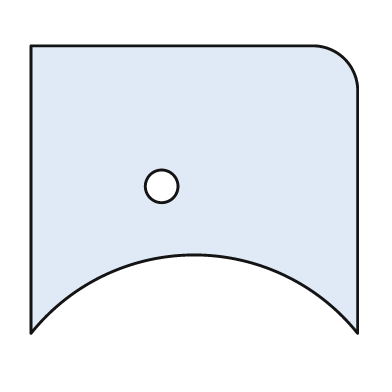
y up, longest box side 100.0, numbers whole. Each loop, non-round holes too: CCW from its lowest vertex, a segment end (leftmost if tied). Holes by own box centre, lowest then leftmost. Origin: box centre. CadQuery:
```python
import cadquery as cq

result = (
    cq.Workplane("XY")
    .moveTo(-50.0, -44.0)
    .threePointArc((0.0, -20.0), (50.0, -44.0))
    .lineTo(50.0, 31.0)
    .threePointArc((46.0, 40.0), (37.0, 44.0))
    .lineTo(-50.0, 44.0)
    .close()
    .moveTo(-10.0, 1.0)
    .circle(5.0)
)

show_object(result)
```